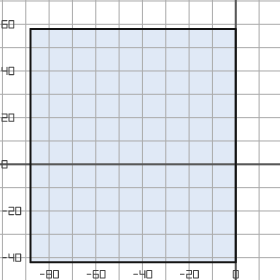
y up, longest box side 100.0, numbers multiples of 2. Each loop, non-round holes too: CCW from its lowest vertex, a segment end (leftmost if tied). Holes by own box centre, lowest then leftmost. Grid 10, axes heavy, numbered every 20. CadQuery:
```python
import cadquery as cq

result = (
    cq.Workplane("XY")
    .moveTo(-88.0, -42.0)
    .lineTo(0.0, -42.0)
    .lineTo(0.0, 58.0)
    .lineTo(-88.0, 58.0)
    .close()
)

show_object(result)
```